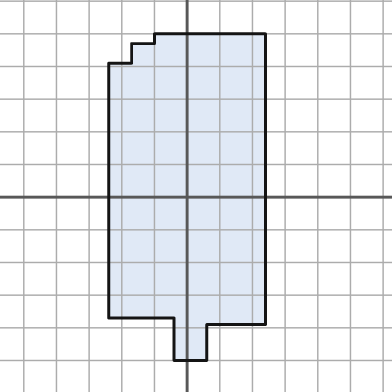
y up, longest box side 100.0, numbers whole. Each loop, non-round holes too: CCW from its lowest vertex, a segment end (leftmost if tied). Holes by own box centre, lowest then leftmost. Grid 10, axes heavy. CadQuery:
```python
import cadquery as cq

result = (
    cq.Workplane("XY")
    .moveTo(-4.0, -50.0)
    .lineTo(6.0, -50.0)
    .lineTo(6.0, -39.0)
    .lineTo(24.0, -39.0)
    .lineTo(24.0, 50.0)
    .lineTo(-10.0, 50.0)
    .lineTo(-10.0, 47.0)
    .lineTo(-17.0, 47.0)
    .lineTo(-17.0, 41.0)
    .lineTo(-24.0, 41.0)
    .lineTo(-24.0, -37.0)
    .lineTo(-4.0, -37.0)
    .close()
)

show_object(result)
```